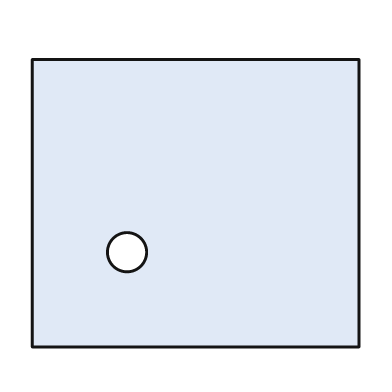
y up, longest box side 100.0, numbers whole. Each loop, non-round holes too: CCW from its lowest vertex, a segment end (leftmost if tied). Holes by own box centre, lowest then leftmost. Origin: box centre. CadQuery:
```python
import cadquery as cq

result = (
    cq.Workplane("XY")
    .moveTo(-50.0, -44.0)
    .lineTo(50.0, -44.0)
    .lineTo(50.0, 44.0)
    .lineTo(-50.0, 44.0)
    .close()
    .moveTo(-21.0, -15.0)
    .circle(6.0)
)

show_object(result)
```